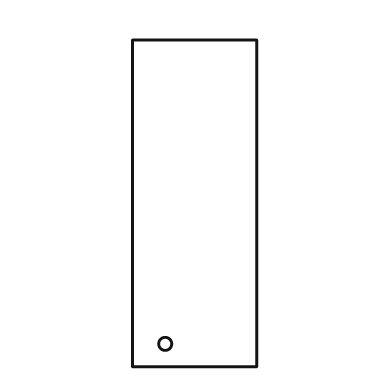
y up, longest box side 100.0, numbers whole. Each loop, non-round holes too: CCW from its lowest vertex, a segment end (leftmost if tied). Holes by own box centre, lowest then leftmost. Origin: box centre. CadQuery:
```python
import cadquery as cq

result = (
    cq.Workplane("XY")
    .moveTo(-19.0, -50.0)
    .lineTo(19.0, -50.0)
    .lineTo(19.0, 50.0)
    .lineTo(-19.0, 50.0)
    .close()
    .moveTo(-9.0, -43.0)
    .circle(2.0)
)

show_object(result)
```